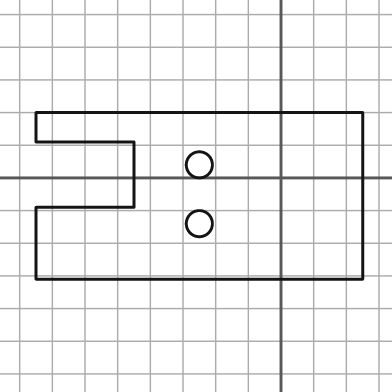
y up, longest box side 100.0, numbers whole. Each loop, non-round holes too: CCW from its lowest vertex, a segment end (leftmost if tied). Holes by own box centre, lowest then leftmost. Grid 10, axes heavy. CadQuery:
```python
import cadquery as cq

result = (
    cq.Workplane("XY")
    .moveTo(-75.0, -31.0)
    .lineTo(25.0, -31.0)
    .lineTo(25.0, 20.0)
    .lineTo(-75.0, 20.0)
    .lineTo(-75.0, 11.0)
    .lineTo(-45.0, 11.0)
    .lineTo(-45.0, -9.0)
    .lineTo(-75.0, -9.0)
    .close()
    .moveTo(-25.0, -14.0)
    .circle(4.0)
    .moveTo(-25.0, 4.0)
    .circle(4.0)
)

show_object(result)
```